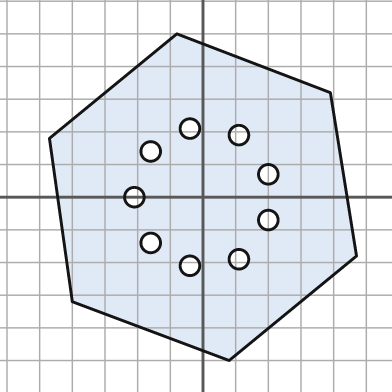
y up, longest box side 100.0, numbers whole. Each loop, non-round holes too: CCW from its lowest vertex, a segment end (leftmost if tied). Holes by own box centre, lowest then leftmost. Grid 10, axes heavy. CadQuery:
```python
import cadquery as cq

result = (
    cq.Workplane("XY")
    .moveTo(8.0, -50.0)
    .lineTo(47.0, -18.0)
    .lineTo(39.0, 32.0)
    .lineTo(-8.0, 50.0)
    .lineTo(-47.0, 18.0)
    .lineTo(-40.0, -32.0)
    .close()
    .moveTo(-4.0, -21.0)
    .circle(3.0)
    .moveTo(11.0, -19.0)
    .circle(3.0)
    .moveTo(-16.0, -14.0)
    .circle(3.0)
    .moveTo(20.0, -7.0)
    .circle(3.0)
    .moveTo(-21.0, 0.0)
    .circle(3.0)
    .moveTo(20.0, 7.0)
    .circle(3.0)
    .moveTo(-16.0, 14.0)
    .circle(3.0)
    .moveTo(11.0, 19.0)
    .circle(3.0)
    .moveTo(-4.0, 21.0)
    .circle(3.0)
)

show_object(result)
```